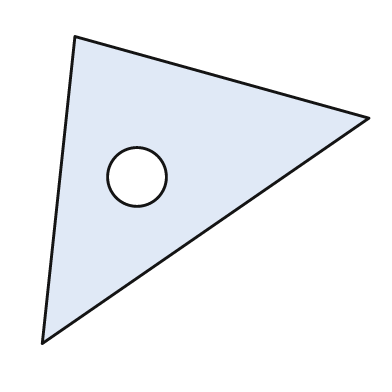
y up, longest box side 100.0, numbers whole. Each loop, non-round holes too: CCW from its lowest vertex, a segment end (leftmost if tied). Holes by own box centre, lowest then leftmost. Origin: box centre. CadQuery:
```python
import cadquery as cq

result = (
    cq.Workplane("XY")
    .moveTo(-50.0, -47.0)
    .lineTo(50.0, 22.0)
    .lineTo(-40.0, 47.0)
    .close()
    .moveTo(-21.0, 4.0)
    .circle(9.0)
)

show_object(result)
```